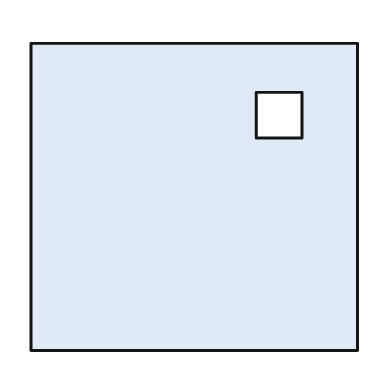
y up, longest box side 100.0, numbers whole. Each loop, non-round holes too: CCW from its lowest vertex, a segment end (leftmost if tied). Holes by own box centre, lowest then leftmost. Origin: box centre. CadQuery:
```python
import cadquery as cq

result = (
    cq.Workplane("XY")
    .moveTo(-50.0, -47.0)
    .lineTo(50.0, -47.0)
    .lineTo(50.0, 47.0)
    .lineTo(-50.0, 47.0)
    .close()
    .moveTo(19.0, 18.0)
    .lineTo(33.0, 18.0)
    .lineTo(33.0, 32.0)
    .lineTo(19.0, 32.0)
    .close()
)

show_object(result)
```